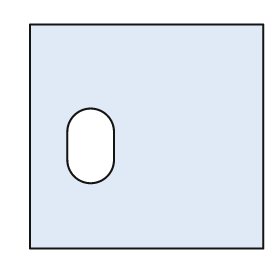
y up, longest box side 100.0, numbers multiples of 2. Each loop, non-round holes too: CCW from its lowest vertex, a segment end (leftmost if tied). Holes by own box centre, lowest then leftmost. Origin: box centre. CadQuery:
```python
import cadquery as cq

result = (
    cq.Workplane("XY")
    .moveTo(-50.0, -48.0)
    .lineTo(50.0, -48.0)
    .lineTo(50.0, 48.0)
    .lineTo(-50.0, 48.0)
    .close()
    .moveTo(-34.0, -10.0)
    .threePointArc((-24.0, -20.0), (-14.0, -10.0))
    .lineTo(-14.0, 2.0)
    .threePointArc((-24.0, 12.0), (-34.0, 2.0))
    .close()
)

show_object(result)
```